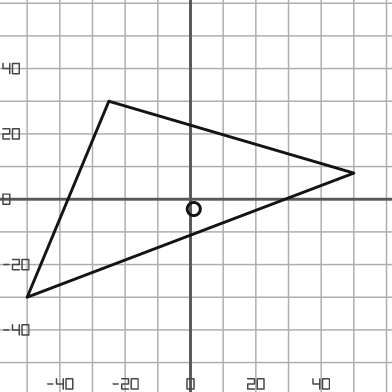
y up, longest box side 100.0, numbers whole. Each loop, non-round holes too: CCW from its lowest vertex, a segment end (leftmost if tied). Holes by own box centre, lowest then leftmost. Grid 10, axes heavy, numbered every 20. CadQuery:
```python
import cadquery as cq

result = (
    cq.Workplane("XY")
    .moveTo(-50.0, -30.0)
    .lineTo(50.0, 8.0)
    .lineTo(-25.0, 30.0)
    .close()
    .moveTo(1.0, -3.0)
    .circle(2.0)
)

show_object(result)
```